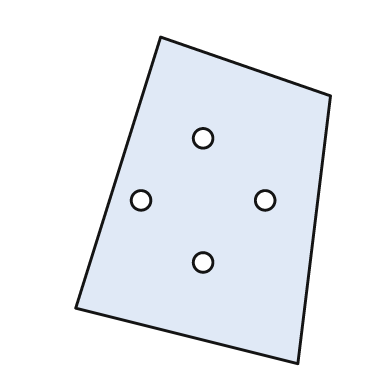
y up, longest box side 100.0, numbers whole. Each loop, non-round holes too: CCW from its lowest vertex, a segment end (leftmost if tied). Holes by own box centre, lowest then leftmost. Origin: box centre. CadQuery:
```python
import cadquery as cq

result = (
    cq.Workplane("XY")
    .moveTo(29.0, -50.0)
    .lineTo(39.0, 32.0)
    .lineTo(-13.0, 50.0)
    .lineTo(-39.0, -33.0)
    .close()
    .moveTo(0.0, -19.0)
    .circle(3.0)
    .moveTo(-19.0, 0.0)
    .circle(3.0)
    .moveTo(19.0, 0.0)
    .circle(3.0)
    .moveTo(0.0, 19.0)
    .circle(3.0)
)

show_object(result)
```